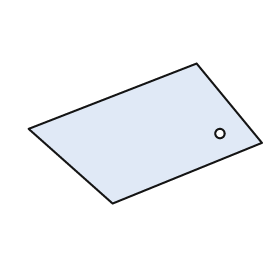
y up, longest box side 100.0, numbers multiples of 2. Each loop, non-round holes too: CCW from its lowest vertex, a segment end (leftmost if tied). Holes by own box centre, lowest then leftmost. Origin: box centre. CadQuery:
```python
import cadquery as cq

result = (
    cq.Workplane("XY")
    .moveTo(-14.0, -30.0)
    .lineTo(50.0, -4.0)
    .lineTo(22.0, 30.0)
    .lineTo(-50.0, 2.0)
    .close()
    .moveTo(32.0, 0.0)
    .circle(2.0)
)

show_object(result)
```